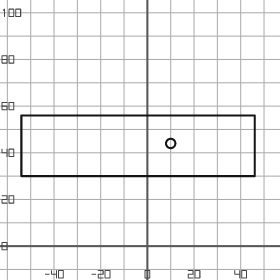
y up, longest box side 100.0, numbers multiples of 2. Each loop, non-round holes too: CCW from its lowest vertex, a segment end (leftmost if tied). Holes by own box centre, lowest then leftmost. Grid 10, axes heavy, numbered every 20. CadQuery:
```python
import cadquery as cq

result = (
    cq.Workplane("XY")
    .moveTo(-54.0, 30.0)
    .lineTo(46.0, 30.0)
    .lineTo(46.0, 56.0)
    .lineTo(-54.0, 56.0)
    .close()
    .moveTo(10.0, 44.0)
    .circle(2.0)
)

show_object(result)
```